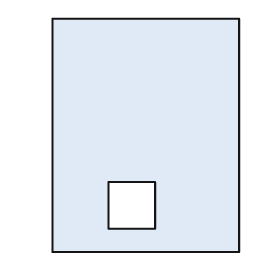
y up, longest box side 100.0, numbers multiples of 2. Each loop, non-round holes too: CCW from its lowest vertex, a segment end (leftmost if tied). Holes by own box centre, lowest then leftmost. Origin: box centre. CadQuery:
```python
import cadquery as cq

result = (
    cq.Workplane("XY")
    .moveTo(-40.0, -50.0)
    .lineTo(40.0, -50.0)
    .lineTo(40.0, 50.0)
    .lineTo(-40.0, 50.0)
    .close()
    .moveTo(-16.0, -40.0)
    .lineTo(4.0, -40.0)
    .lineTo(4.0, -20.0)
    .lineTo(-16.0, -20.0)
    .close()
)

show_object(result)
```